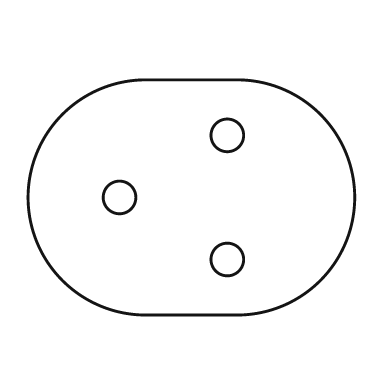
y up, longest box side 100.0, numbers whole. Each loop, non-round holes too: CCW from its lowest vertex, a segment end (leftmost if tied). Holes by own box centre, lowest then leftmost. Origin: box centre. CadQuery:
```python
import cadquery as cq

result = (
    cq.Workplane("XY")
    .moveTo(-14.0, -36.0)
    .lineTo(14.0, -36.0)
    .threePointArc((50.0, 0.0), (14.0, 36.0))
    .lineTo(-14.0, 36.0)
    .threePointArc((-50.0, 0.0), (-14.0, -36.0))
    .close()
    .moveTo(11.0, -19.0)
    .circle(5.0)
    .moveTo(-22.0, 0.0)
    .circle(5.0)
    .moveTo(11.0, 19.0)
    .circle(5.0)
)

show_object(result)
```